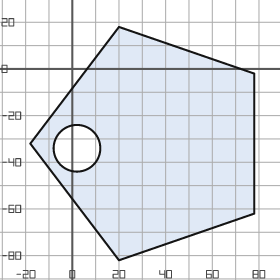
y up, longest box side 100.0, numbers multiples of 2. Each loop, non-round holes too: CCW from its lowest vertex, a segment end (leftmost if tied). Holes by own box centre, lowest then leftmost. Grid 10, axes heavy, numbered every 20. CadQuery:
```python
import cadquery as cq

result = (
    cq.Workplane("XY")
    .moveTo(20.0, -82.0)
    .lineTo(78.0, -62.0)
    .lineTo(78.0, -2.0)
    .lineTo(20.0, 18.0)
    .lineTo(-18.0, -32.0)
    .close()
    .moveTo(2.0, -34.0)
    .circle(10.0)
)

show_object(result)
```